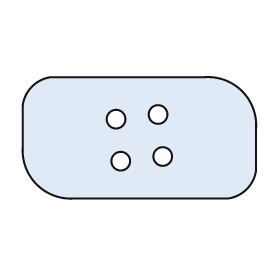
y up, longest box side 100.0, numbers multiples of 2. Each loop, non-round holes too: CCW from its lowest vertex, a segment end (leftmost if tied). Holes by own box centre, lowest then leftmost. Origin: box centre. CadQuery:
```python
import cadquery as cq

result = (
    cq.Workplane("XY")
    .moveTo(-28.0, -26.0)
    .lineTo(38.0, -26.0)
    .threePointArc((46.0, -22.0), (50.0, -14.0))
    .lineTo(50.0, 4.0)
    .threePointArc((44.0, 20.0), (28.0, 26.0))
    .lineTo(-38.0, 26.0)
    .threePointArc((-46.0, 22.0), (-50.0, 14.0))
    .lineTo(-50.0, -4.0)
    .threePointArc((-44.0, -20.0), (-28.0, -26.0))
    .close()
    .moveTo(-8.0, -10.0)
    .circle(4.0)
    .moveTo(10.0, -8.0)
    .circle(4.0)
    .moveTo(-10.0, 8.0)
    .circle(4.0)
    .moveTo(8.0, 10.0)
    .circle(4.0)
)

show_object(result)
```